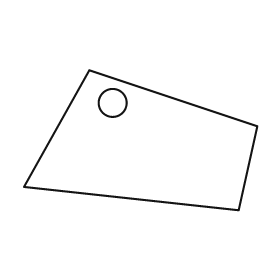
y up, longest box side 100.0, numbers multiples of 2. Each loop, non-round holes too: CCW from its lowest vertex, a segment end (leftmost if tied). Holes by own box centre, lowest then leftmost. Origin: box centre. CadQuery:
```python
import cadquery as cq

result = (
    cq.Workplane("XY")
    .moveTo(42.0, -30.0)
    .lineTo(50.0, 6.0)
    .lineTo(-22.0, 30.0)
    .lineTo(-50.0, -20.0)
    .close()
    .moveTo(-12.0, 16.0)
    .circle(6.0)
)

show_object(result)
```